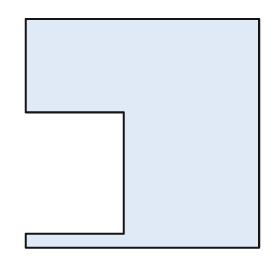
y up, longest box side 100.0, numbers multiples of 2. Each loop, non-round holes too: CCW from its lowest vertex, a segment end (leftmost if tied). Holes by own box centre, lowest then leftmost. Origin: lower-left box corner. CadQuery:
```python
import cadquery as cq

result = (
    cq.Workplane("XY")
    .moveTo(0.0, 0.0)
    .lineTo(100.0, 0.0)
    .lineTo(100.0, 98.0)
    .lineTo(0.0, 98.0)
    .lineTo(0.0, 58.0)
    .lineTo(42.0, 58.0)
    .lineTo(42.0, 6.0)
    .lineTo(0.0, 6.0)
    .close()
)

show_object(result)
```